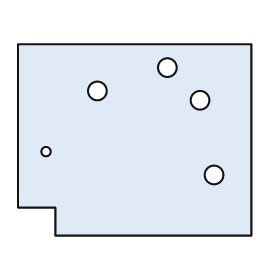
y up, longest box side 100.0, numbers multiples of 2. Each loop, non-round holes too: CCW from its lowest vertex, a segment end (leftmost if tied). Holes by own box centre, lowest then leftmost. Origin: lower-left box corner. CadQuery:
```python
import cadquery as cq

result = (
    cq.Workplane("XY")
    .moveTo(16.0, 0.0)
    .lineTo(100.0, 0.0)
    .lineTo(100.0, 82.0)
    .lineTo(0.0, 82.0)
    .lineTo(0.0, 12.0)
    .lineTo(16.0, 12.0)
    .close()
    .moveTo(84.0, 26.0)
    .circle(4.0)
    .moveTo(12.0, 36.0)
    .circle(2.0)
    .moveTo(78.0, 58.0)
    .circle(4.0)
    .moveTo(34.0, 62.0)
    .circle(4.0)
    .moveTo(64.0, 72.0)
    .circle(4.0)
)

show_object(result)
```